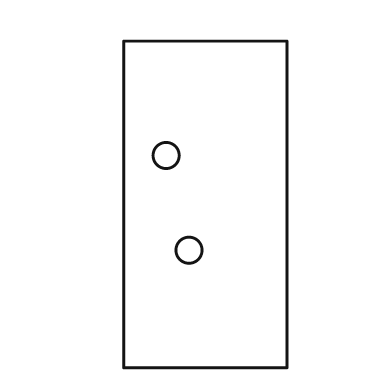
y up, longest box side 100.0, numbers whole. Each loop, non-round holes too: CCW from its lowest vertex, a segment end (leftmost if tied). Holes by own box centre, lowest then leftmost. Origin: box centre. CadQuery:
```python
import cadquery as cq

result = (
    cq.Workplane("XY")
    .moveTo(-25.0, -50.0)
    .lineTo(25.0, -50.0)
    .lineTo(25.0, 50.0)
    .lineTo(-25.0, 50.0)
    .close()
    .moveTo(-5.0, -14.0)
    .circle(4.0)
    .moveTo(-12.0, 15.0)
    .circle(4.0)
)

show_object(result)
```